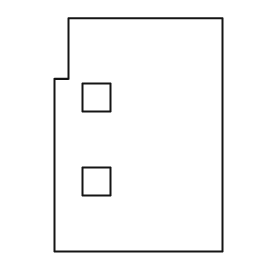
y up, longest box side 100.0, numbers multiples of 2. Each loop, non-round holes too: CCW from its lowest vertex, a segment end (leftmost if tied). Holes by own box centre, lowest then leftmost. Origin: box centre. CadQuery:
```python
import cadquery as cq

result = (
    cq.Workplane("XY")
    .moveTo(-36.0, -50.0)
    .lineTo(36.0, -50.0)
    .lineTo(36.0, 50.0)
    .lineTo(-30.0, 50.0)
    .lineTo(-30.0, 24.0)
    .lineTo(-36.0, 24.0)
    .close()
    .moveTo(-24.0, -26.0)
    .lineTo(-12.0, -26.0)
    .lineTo(-12.0, -14.0)
    .lineTo(-24.0, -14.0)
    .close()
    .moveTo(-24.0, 10.0)
    .lineTo(-12.0, 10.0)
    .lineTo(-12.0, 22.0)
    .lineTo(-24.0, 22.0)
    .close()
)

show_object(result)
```